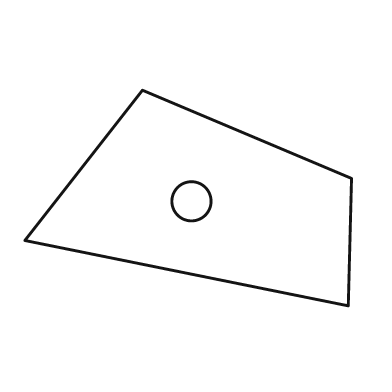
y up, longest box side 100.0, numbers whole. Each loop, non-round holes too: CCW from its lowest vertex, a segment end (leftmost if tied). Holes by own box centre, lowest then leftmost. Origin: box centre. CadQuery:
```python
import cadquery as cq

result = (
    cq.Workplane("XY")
    .moveTo(49.0, -33.0)
    .lineTo(50.0, 6.0)
    .lineTo(-14.0, 33.0)
    .lineTo(-50.0, -13.0)
    .close()
    .moveTo(1.0, -1.0)
    .circle(6.0)
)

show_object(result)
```